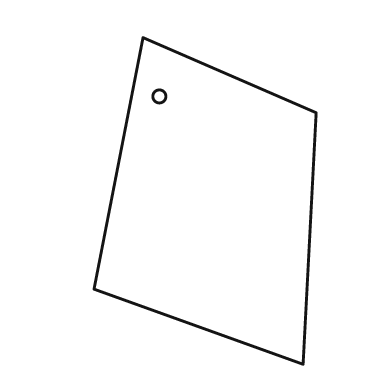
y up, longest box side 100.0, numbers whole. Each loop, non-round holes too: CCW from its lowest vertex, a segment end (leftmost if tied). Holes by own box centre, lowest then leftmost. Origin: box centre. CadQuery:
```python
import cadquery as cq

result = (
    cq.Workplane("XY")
    .moveTo(30.0, -50.0)
    .lineTo(34.0, 27.0)
    .lineTo(-19.0, 50.0)
    .lineTo(-34.0, -27.0)
    .close()
    .moveTo(-14.0, 32.0)
    .circle(2.0)
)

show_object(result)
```